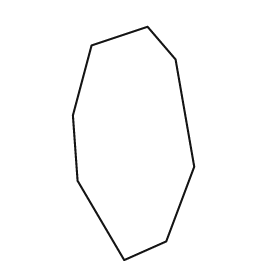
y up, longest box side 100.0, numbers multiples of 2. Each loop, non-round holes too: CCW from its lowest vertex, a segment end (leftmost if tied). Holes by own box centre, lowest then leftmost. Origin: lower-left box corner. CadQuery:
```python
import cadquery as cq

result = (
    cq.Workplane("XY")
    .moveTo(22.0, 0.0)
    .lineTo(40.0, 8.0)
    .lineTo(52.0, 40.0)
    .lineTo(44.0, 86.0)
    .lineTo(32.0, 100.0)
    .lineTo(8.0, 92.0)
    .lineTo(0.0, 62.0)
    .lineTo(2.0, 34.0)
    .close()
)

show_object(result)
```